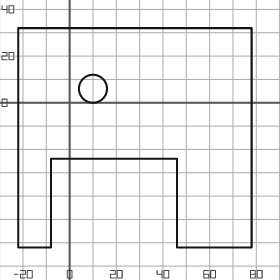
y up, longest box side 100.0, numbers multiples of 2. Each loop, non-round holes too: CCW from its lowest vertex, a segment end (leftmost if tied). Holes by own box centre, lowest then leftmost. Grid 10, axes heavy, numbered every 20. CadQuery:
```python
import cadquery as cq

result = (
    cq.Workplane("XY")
    .moveTo(-22.0, -62.0)
    .lineTo(-8.0, -62.0)
    .lineTo(-8.0, -24.0)
    .lineTo(46.0, -24.0)
    .lineTo(46.0, -62.0)
    .lineTo(78.0, -62.0)
    .lineTo(78.0, 32.0)
    .lineTo(-22.0, 32.0)
    .close()
    .moveTo(10.0, 6.0)
    .circle(6.0)
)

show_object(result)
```